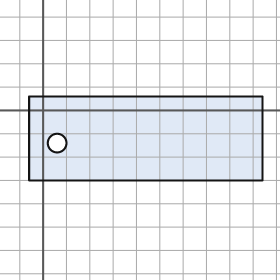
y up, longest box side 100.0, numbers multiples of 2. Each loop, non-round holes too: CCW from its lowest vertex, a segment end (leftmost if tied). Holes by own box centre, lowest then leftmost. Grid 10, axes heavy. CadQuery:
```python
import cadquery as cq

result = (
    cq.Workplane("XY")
    .moveTo(-6.0, -30.0)
    .lineTo(94.0, -30.0)
    .lineTo(94.0, 6.0)
    .lineTo(-6.0, 6.0)
    .close()
    .moveTo(6.0, -14.0)
    .circle(4.0)
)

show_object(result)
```